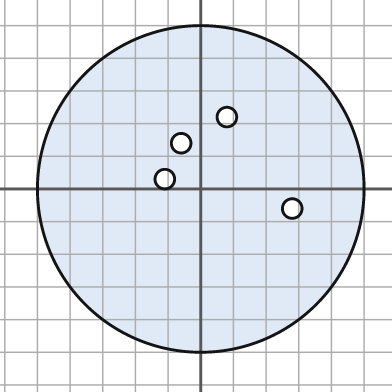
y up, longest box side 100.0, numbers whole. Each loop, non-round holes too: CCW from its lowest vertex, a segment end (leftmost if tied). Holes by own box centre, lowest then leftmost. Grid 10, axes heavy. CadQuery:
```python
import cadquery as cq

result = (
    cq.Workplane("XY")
    .moveTo(0.0, 0.0)
    .circle(50.0)
    .moveTo(28.0, -6.0)
    .circle(3.0)
    .moveTo(-11.0, 3.0)
    .circle(3.0)
    .moveTo(-6.0, 14.0)
    .circle(3.0)
    .moveTo(8.0, 22.0)
    .circle(3.0)
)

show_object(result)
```